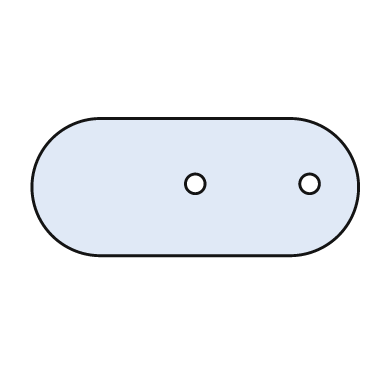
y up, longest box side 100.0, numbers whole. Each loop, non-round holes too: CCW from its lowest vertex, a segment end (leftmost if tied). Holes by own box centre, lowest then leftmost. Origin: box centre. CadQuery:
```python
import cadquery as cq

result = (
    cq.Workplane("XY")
    .moveTo(-29.0, -21.0)
    .lineTo(29.0, -21.0)
    .threePointArc((50.0, 0.0), (29.0, 21.0))
    .lineTo(-29.0, 21.0)
    .threePointArc((-50.0, 0.0), (-29.0, -21.0))
    .close()
    .moveTo(0.0, 1.0)
    .circle(3.0)
    .moveTo(35.0, 1.0)
    .circle(3.0)
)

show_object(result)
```